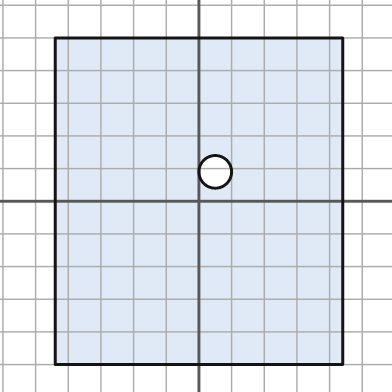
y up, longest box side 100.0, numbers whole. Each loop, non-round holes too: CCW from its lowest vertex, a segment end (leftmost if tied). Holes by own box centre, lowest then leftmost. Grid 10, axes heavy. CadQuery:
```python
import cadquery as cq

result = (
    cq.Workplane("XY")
    .moveTo(-44.0, -50.0)
    .lineTo(44.0, -50.0)
    .lineTo(44.0, 50.0)
    .lineTo(-44.0, 50.0)
    .close()
    .moveTo(5.0, 9.0)
    .circle(5.0)
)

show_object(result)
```